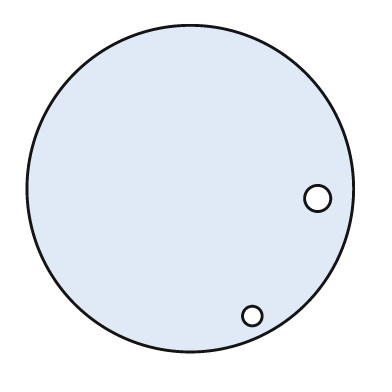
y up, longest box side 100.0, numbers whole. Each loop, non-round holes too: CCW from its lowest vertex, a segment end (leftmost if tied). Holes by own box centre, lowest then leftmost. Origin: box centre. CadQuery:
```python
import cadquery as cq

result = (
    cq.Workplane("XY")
    .moveTo(0.0, 0.0)
    .circle(50.0)
    .moveTo(19.0, -39.0)
    .circle(3.0)
    .moveTo(39.0, -3.0)
    .circle(4.0)
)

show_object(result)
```